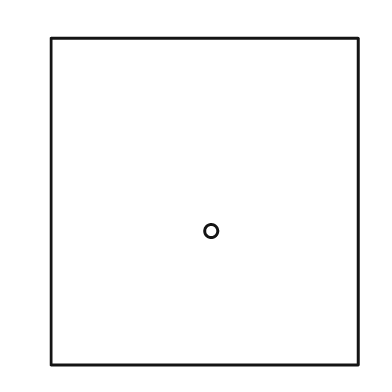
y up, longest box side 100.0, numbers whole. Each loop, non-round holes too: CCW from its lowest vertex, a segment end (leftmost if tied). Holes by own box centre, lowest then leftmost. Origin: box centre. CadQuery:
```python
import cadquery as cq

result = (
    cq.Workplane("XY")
    .moveTo(-47.0, -50.0)
    .lineTo(47.0, -50.0)
    .lineTo(47.0, 50.0)
    .lineTo(-47.0, 50.0)
    .close()
    .moveTo(2.0, -9.0)
    .circle(2.0)
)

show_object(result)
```